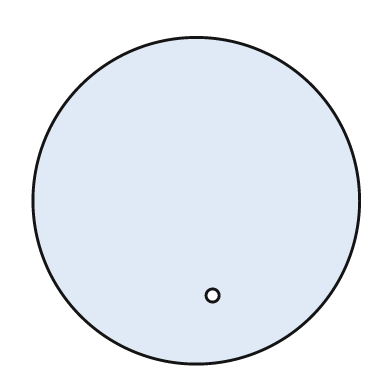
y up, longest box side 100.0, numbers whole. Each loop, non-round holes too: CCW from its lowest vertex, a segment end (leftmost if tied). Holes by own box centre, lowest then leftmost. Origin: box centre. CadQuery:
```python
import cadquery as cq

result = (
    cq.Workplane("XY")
    .moveTo(0.0, 0.0)
    .circle(50.0)
    .moveTo(5.0, -29.0)
    .circle(2.0)
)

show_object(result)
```